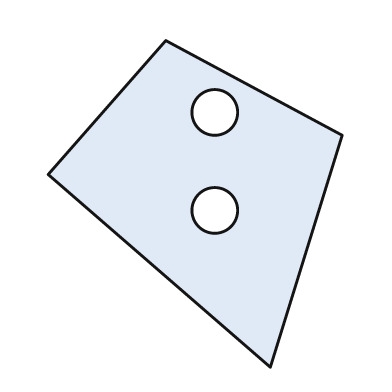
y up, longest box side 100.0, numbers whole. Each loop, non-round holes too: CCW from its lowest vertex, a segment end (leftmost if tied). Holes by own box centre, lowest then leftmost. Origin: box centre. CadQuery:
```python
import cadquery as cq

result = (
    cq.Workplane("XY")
    .moveTo(23.0, -50.0)
    .lineTo(45.0, 21.0)
    .lineTo(-9.0, 50.0)
    .lineTo(-45.0, 9.0)
    .close()
    .moveTo(6.0, -2.0)
    .circle(7.0)
    .moveTo(6.0, 28.0)
    .circle(7.0)
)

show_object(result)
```